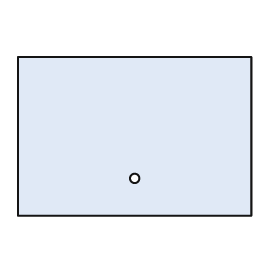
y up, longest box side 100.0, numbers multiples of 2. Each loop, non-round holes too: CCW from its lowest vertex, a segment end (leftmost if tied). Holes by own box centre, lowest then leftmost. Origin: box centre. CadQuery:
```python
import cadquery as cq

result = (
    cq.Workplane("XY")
    .moveTo(-50.0, -34.0)
    .lineTo(50.0, -34.0)
    .lineTo(50.0, 34.0)
    .lineTo(-50.0, 34.0)
    .close()
    .moveTo(0.0, -18.0)
    .circle(2.0)
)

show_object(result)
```